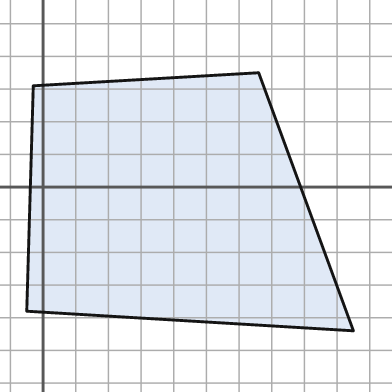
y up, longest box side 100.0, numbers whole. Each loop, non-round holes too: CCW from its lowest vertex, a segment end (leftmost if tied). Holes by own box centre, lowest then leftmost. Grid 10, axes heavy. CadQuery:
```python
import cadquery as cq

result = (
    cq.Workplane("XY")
    .moveTo(95.0, -44.0)
    .lineTo(66.0, 35.0)
    .lineTo(-3.0, 31.0)
    .lineTo(-5.0, -38.0)
    .close()
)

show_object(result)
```